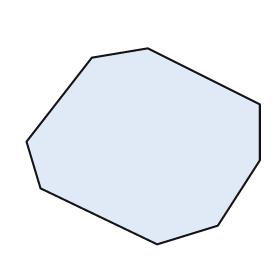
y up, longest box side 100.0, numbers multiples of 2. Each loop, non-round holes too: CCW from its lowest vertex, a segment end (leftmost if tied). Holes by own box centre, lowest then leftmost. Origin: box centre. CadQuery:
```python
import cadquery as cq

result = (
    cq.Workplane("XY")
    .moveTo(6.0, -42.0)
    .lineTo(32.0, -34.0)
    .lineTo(50.0, -6.0)
    .lineTo(50.0, 18.0)
    .lineTo(2.0, 42.0)
    .lineTo(-22.0, 38.0)
    .lineTo(-50.0, 2.0)
    .lineTo(-44.0, -18.0)
    .close()
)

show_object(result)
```